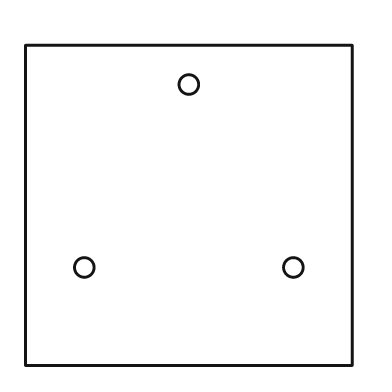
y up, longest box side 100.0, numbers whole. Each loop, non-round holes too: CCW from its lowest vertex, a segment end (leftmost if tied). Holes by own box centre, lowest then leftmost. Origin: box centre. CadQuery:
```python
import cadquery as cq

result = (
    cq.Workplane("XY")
    .moveTo(-50.0, -49.0)
    .lineTo(50.0, -49.0)
    .lineTo(50.0, 49.0)
    .lineTo(-50.0, 49.0)
    .close()
    .moveTo(-32.0, -19.0)
    .circle(3.0)
    .moveTo(32.0, -19.0)
    .circle(3.0)
    .moveTo(0.0, 37.0)
    .circle(3.0)
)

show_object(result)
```